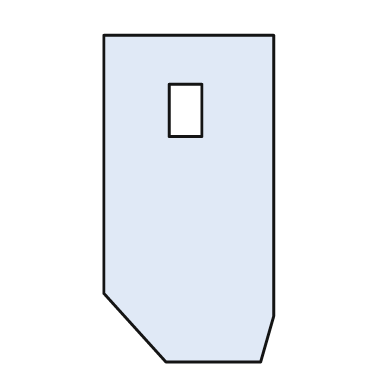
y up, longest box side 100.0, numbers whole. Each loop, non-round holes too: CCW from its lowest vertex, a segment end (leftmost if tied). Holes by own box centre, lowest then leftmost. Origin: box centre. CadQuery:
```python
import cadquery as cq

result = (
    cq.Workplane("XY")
    .moveTo(-7.0, -50.0)
    .lineTo(22.0, -50.0)
    .lineTo(26.0, -36.0)
    .lineTo(26.0, 50.0)
    .lineTo(-26.0, 50.0)
    .lineTo(-26.0, -29.0)
    .close()
    .moveTo(-6.0, 19.0)
    .lineTo(4.0, 19.0)
    .lineTo(4.0, 35.0)
    .lineTo(-6.0, 35.0)
    .close()
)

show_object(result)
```